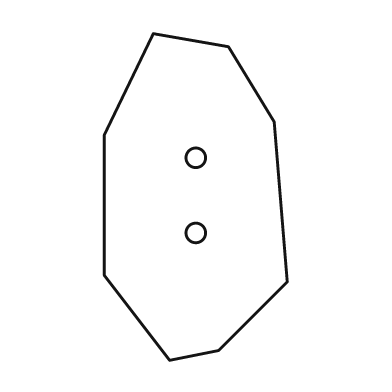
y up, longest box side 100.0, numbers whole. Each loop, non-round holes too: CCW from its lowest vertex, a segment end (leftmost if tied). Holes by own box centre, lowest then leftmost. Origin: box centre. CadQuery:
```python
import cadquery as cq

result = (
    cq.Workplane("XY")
    .moveTo(-8.0, -50.0)
    .lineTo(7.0, -47.0)
    .lineTo(28.0, -26.0)
    .lineTo(24.0, 23.0)
    .lineTo(10.0, 46.0)
    .lineTo(-13.0, 50.0)
    .lineTo(-28.0, 19.0)
    .lineTo(-28.0, -24.0)
    .close()
    .moveTo(0.0, -11.0)
    .circle(3.0)
    .moveTo(0.0, 12.0)
    .circle(3.0)
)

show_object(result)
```